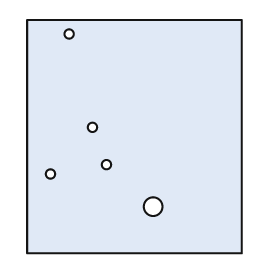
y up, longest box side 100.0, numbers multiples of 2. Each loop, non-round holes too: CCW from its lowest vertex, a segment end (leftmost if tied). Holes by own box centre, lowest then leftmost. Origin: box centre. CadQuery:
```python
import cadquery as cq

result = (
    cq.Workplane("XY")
    .moveTo(-46.0, -50.0)
    .lineTo(46.0, -50.0)
    .lineTo(46.0, 50.0)
    .lineTo(-46.0, 50.0)
    .close()
    .moveTo(8.0, -30.0)
    .circle(4.0)
    .moveTo(-36.0, -16.0)
    .circle(2.0)
    .moveTo(-12.0, -12.0)
    .circle(2.0)
    .moveTo(-18.0, 4.0)
    .circle(2.0)
    .moveTo(-28.0, 44.0)
    .circle(2.0)
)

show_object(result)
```